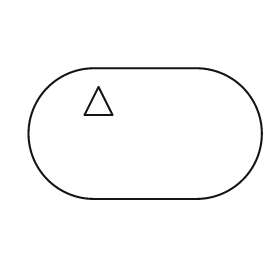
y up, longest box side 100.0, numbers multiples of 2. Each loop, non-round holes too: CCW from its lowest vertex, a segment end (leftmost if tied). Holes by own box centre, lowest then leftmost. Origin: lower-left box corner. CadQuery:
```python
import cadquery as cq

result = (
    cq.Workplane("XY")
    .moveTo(28.0, 0.0)
    .lineTo(72.0, 0.0)
    .threePointArc((100.0, 28.0), (72.0, 56.0))
    .lineTo(28.0, 56.0)
    .threePointArc((0.0, 28.0), (28.0, 0.0))
    .close()
    .moveTo(24.0, 36.0)
    .lineTo(36.0, 36.0)
    .lineTo(30.0, 48.0)
    .close()
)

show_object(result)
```